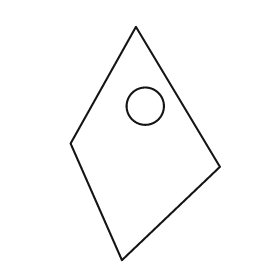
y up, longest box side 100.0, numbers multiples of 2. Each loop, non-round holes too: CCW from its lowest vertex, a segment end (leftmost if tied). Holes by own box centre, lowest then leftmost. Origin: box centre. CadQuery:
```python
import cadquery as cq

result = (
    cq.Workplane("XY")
    .moveTo(-10.0, -50.0)
    .lineTo(32.0, -10.0)
    .lineTo(-4.0, 50.0)
    .lineTo(-32.0, 0.0)
    .close()
    .moveTo(0.0, 16.0)
    .circle(8.0)
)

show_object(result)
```